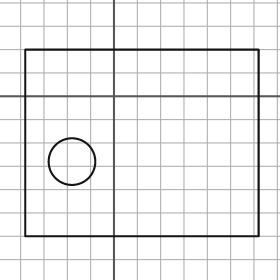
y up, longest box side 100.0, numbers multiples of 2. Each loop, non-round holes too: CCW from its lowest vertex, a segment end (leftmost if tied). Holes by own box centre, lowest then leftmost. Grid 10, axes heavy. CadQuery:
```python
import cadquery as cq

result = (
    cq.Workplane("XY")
    .moveTo(-38.0, -60.0)
    .lineTo(62.0, -60.0)
    .lineTo(62.0, 20.0)
    .lineTo(-38.0, 20.0)
    .close()
    .moveTo(-18.0, -28.0)
    .circle(10.0)
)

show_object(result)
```